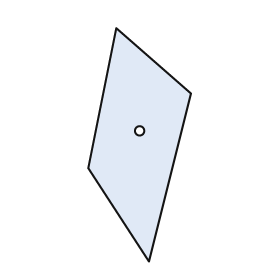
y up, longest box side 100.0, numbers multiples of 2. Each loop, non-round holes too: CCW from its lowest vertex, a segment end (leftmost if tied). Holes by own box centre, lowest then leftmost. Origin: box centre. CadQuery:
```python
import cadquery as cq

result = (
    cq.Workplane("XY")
    .moveTo(4.0, -50.0)
    .lineTo(22.0, 22.0)
    .lineTo(-10.0, 50.0)
    .lineTo(-22.0, -10.0)
    .close()
    .moveTo(0.0, 6.0)
    .circle(2.0)
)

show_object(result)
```